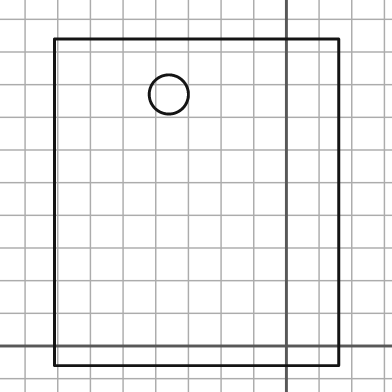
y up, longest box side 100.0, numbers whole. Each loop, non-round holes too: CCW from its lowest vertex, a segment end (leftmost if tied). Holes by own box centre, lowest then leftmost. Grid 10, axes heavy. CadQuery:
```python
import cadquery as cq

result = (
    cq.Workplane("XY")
    .moveTo(-71.0, -6.0)
    .lineTo(16.0, -6.0)
    .lineTo(16.0, 94.0)
    .lineTo(-71.0, 94.0)
    .close()
    .moveTo(-36.0, 77.0)
    .circle(6.0)
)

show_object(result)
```